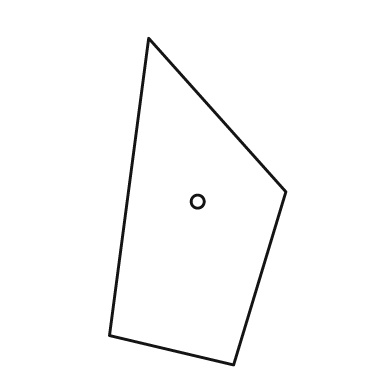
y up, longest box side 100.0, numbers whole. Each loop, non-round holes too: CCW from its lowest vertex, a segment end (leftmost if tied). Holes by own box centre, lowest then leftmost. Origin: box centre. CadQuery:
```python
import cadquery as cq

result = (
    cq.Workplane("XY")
    .moveTo(11.0, -50.0)
    .lineTo(27.0, 3.0)
    .lineTo(-15.0, 50.0)
    .lineTo(-27.0, -41.0)
    .close()
    .moveTo(0.0, 0.0)
    .circle(2.0)
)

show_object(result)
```